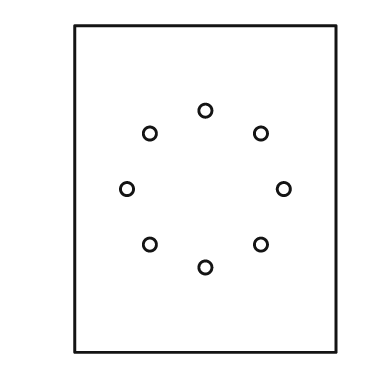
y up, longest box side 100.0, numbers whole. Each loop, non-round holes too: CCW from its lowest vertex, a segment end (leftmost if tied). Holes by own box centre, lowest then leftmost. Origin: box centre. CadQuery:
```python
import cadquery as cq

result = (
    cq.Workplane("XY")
    .moveTo(-40.0, -50.0)
    .lineTo(40.0, -50.0)
    .lineTo(40.0, 50.0)
    .lineTo(-40.0, 50.0)
    .close()
    .moveTo(0.0, -24.0)
    .circle(2.0)
    .moveTo(-17.0, -17.0)
    .circle(2.0)
    .moveTo(17.0, -17.0)
    .circle(2.0)
    .moveTo(-24.0, 0.0)
    .circle(2.0)
    .moveTo(24.0, 0.0)
    .circle(2.0)
    .moveTo(-17.0, 17.0)
    .circle(2.0)
    .moveTo(17.0, 17.0)
    .circle(2.0)
    .moveTo(0.0, 24.0)
    .circle(2.0)
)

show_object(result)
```